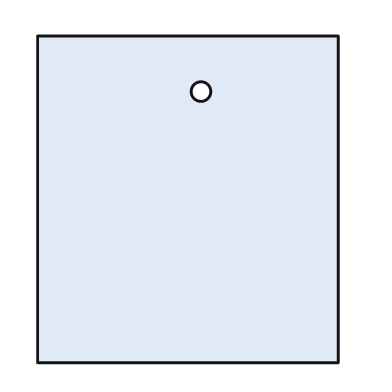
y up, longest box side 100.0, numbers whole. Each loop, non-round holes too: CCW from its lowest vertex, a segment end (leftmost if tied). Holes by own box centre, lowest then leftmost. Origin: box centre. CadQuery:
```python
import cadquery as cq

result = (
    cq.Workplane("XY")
    .moveTo(-46.0, -50.0)
    .lineTo(46.0, -50.0)
    .lineTo(46.0, 50.0)
    .lineTo(-46.0, 50.0)
    .close()
    .moveTo(4.0, 33.0)
    .circle(3.0)
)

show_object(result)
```